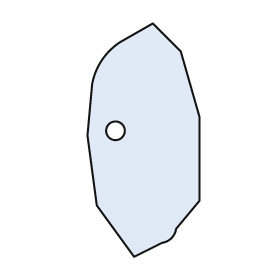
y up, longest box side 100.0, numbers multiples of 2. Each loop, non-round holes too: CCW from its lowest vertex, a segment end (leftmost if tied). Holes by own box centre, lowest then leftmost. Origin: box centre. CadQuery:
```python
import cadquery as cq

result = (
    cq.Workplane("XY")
    .moveTo(-4.0, -50.0)
    .lineTo(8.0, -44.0)
    .threePointArc((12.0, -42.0), (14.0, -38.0))
    .lineTo(24.0, -26.0)
    .lineTo(24.0, 10.0)
    .lineTo(16.0, 38.0)
    .lineTo(4.0, 50.0)
    .lineTo(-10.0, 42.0)
    .threePointArc((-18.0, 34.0), (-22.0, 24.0))
    .lineTo(-24.0, 2.0)
    .lineTo(-20.0, -28.0)
    .close()
    .moveTo(-12.0, 4.0)
    .circle(4.0)
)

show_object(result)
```